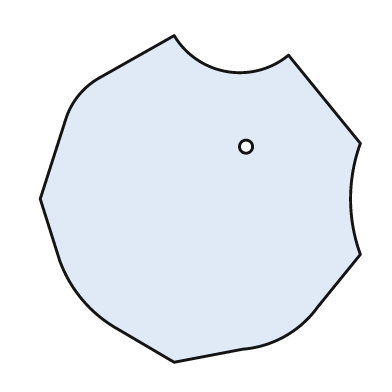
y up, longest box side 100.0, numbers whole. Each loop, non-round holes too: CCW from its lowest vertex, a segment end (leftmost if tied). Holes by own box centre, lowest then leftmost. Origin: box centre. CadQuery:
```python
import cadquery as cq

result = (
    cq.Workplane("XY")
    .moveTo(-8.0, -50.0)
    .lineTo(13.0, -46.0)
    .threePointArc((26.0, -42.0), (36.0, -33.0))
    .lineTo(49.0, -17.0)
    .threePointArc((46.0, 0.0), (49.0, 17.0))
    .lineTo(27.0, 44.0)
    .threePointArc((8.0, 39.0), (-8.0, 50.0))
    .lineTo(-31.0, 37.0)
    .threePointArc((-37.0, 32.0), (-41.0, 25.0))
    .lineTo(-49.0, 0.0)
    .lineTo(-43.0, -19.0)
    .threePointArc((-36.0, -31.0), (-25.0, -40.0))
    .close()
    .moveTo(14.0, 16.0)
    .circle(2.0)
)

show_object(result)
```